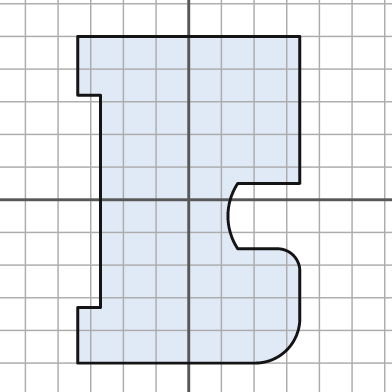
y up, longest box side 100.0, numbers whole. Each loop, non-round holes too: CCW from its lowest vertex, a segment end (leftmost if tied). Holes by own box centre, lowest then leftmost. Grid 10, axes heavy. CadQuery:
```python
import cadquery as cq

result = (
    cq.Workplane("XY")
    .moveTo(-34.0, -50.0)
    .lineTo(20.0, -50.0)
    .threePointArc((30.0, -46.0), (34.0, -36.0))
    .lineTo(34.0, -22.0)
    .threePointArc((32.0, -17.0), (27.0, -15.0))
    .lineTo(15.0, -15.0)
    .threePointArc((12.0, -5.0), (15.0, 5.0))
    .lineTo(34.0, 5.0)
    .lineTo(34.0, 50.0)
    .lineTo(-34.0, 50.0)
    .lineTo(-34.0, 32.0)
    .lineTo(-27.0, 32.0)
    .lineTo(-27.0, -33.0)
    .lineTo(-34.0, -33.0)
    .close()
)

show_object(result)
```